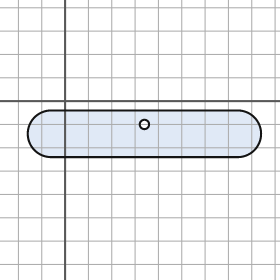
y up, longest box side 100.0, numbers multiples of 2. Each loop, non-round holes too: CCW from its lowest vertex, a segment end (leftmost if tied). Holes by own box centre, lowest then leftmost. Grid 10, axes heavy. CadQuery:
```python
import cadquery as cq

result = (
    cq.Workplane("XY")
    .moveTo(-6.0, -24.0)
    .lineTo(74.0, -24.0)
    .threePointArc((84.0, -14.0), (74.0, -4.0))
    .lineTo(-6.0, -4.0)
    .threePointArc((-16.0, -14.0), (-6.0, -24.0))
    .close()
    .moveTo(34.0, -10.0)
    .circle(2.0)
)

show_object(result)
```